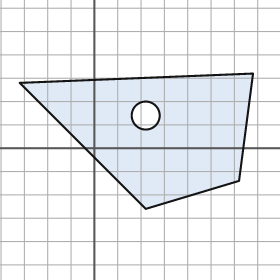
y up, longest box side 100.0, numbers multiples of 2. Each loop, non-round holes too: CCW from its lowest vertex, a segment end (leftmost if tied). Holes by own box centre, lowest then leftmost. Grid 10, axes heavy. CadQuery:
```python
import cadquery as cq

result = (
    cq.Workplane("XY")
    .moveTo(22.0, -26.0)
    .lineTo(62.0, -14.0)
    .lineTo(68.0, 32.0)
    .lineTo(-32.0, 28.0)
    .close()
    .moveTo(22.0, 14.0)
    .circle(6.0)
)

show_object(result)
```